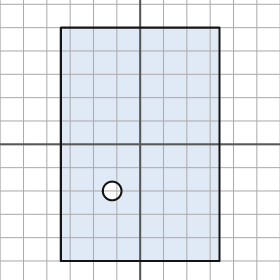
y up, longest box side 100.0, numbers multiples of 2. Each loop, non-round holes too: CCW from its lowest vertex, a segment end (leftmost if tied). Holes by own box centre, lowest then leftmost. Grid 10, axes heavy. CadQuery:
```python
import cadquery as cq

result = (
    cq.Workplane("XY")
    .moveTo(-34.0, -50.0)
    .lineTo(34.0, -50.0)
    .lineTo(34.0, 50.0)
    .lineTo(-34.0, 50.0)
    .close()
    .moveTo(-12.0, -20.0)
    .circle(4.0)
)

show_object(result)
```